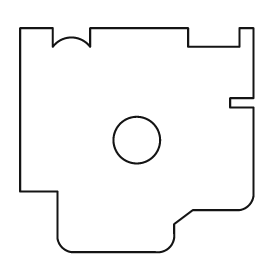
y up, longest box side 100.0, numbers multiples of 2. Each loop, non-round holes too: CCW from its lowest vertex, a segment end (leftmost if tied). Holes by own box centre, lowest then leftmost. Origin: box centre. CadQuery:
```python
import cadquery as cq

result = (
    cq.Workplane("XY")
    .moveTo(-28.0, -48.0)
    .lineTo(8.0, -48.0)
    .threePointArc((14.0, -46.0), (16.0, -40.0))
    .lineTo(16.0, -36.0)
    .lineTo(24.0, -30.0)
    .lineTo(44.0, -30.0)
    .threePointArc((48.0, -28.0), (50.0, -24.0))
    .lineTo(50.0, 14.0)
    .lineTo(40.0, 14.0)
    .lineTo(40.0, 18.0)
    .lineTo(50.0, 18.0)
    .lineTo(50.0, 48.0)
    .lineTo(44.0, 48.0)
    .lineTo(44.0, 40.0)
    .lineTo(22.0, 40.0)
    .lineTo(22.0, 48.0)
    .lineTo(-20.0, 48.0)
    .lineTo(-20.0, 40.0)
    .threePointArc((-28.0, 44.0), (-36.0, 40.0))
    .lineTo(-36.0, 48.0)
    .lineTo(-50.0, 48.0)
    .lineTo(-50.0, -22.0)
    .lineTo(-34.0, -22.0)
    .lineTo(-34.0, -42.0)
    .threePointArc((-32.0, -46.0), (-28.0, -48.0))
    .close()
    .moveTo(0.0, 0.0)
    .circle(10.0)
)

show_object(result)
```